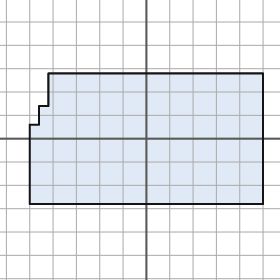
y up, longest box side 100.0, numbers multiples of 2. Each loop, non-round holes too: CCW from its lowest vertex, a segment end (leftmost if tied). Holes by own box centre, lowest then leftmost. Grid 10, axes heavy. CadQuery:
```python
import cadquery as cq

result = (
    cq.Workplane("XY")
    .moveTo(-50.0, -28.0)
    .lineTo(50.0, -28.0)
    .lineTo(50.0, 28.0)
    .lineTo(-42.0, 28.0)
    .lineTo(-42.0, 14.0)
    .lineTo(-46.0, 14.0)
    .lineTo(-46.0, 6.0)
    .lineTo(-50.0, 6.0)
    .close()
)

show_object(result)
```